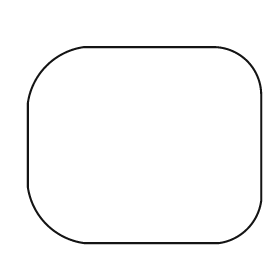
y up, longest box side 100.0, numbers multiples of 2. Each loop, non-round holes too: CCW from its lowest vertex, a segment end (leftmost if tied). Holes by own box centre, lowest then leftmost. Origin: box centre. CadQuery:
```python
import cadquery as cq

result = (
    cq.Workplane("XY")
    .moveTo(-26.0, -42.0)
    .lineTo(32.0, -42.0)
    .threePointArc((44.0, -36.0), (50.0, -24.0))
    .lineTo(50.0, 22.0)
    .threePointArc((44.0, 36.0), (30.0, 42.0))
    .lineTo(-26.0, 42.0)
    .threePointArc((-42.0, 34.0), (-50.0, 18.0))
    .lineTo(-50.0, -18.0)
    .threePointArc((-42.0, -34.0), (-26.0, -42.0))
    .close()
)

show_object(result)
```